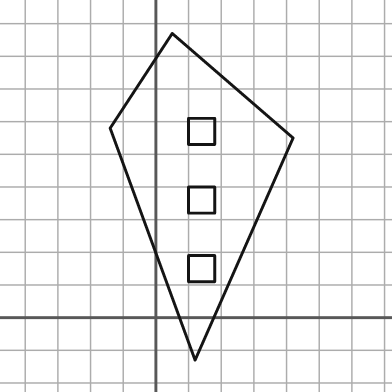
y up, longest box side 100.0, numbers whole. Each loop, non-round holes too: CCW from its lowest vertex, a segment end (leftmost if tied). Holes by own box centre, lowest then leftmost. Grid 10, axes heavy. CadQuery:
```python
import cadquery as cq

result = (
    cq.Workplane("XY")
    .moveTo(12.0, -13.0)
    .lineTo(42.0, 55.0)
    .lineTo(5.0, 87.0)
    .lineTo(-14.0, 58.0)
    .close()
    .moveTo(10.0, 11.0)
    .lineTo(18.0, 11.0)
    .lineTo(18.0, 19.0)
    .lineTo(10.0, 19.0)
    .close()
    .moveTo(10.0, 32.0)
    .lineTo(18.0, 32.0)
    .lineTo(18.0, 40.0)
    .lineTo(10.0, 40.0)
    .close()
    .moveTo(10.0, 53.0)
    .lineTo(18.0, 53.0)
    .lineTo(18.0, 61.0)
    .lineTo(10.0, 61.0)
    .close()
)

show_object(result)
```